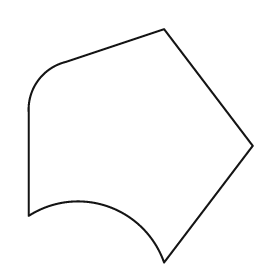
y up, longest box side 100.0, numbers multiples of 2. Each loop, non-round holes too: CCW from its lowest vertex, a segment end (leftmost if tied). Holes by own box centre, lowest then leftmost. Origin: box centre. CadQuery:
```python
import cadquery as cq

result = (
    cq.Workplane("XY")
    .moveTo(10.0, -50.0)
    .lineTo(48.0, 0.0)
    .lineTo(10.0, 50.0)
    .lineTo(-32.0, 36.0)
    .threePointArc((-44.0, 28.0), (-48.0, 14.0))
    .lineTo(-48.0, -30.0)
    .threePointArc((-14.0, -26.0), (10.0, -50.0))
    .close()
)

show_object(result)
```